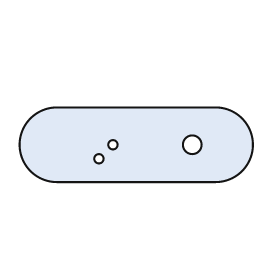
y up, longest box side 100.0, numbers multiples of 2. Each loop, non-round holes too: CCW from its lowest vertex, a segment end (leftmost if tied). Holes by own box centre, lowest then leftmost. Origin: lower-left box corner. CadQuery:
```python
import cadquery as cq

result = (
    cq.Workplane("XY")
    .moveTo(16.0, 0.0)
    .lineTo(84.0, 0.0)
    .threePointArc((100.0, 16.0), (84.0, 32.0))
    .lineTo(16.0, 32.0)
    .threePointArc((0.0, 16.0), (16.0, 0.0))
    .close()
    .moveTo(34.0, 10.0)
    .circle(2.0)
    .moveTo(40.0, 16.0)
    .circle(2.0)
    .moveTo(74.0, 16.0)
    .circle(4.0)
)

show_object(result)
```